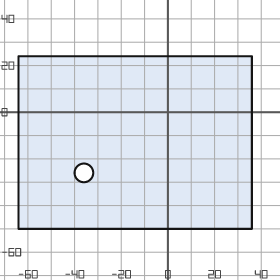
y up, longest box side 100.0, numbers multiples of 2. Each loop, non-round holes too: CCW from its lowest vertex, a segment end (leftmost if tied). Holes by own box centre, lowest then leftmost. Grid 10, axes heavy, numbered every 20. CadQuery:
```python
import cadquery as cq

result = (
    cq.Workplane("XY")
    .moveTo(-64.0, -50.0)
    .lineTo(36.0, -50.0)
    .lineTo(36.0, 24.0)
    .lineTo(-64.0, 24.0)
    .close()
    .moveTo(-36.0, -26.0)
    .circle(4.0)
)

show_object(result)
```